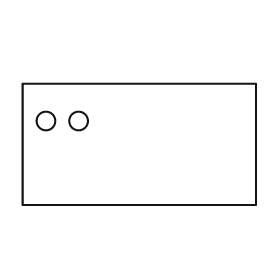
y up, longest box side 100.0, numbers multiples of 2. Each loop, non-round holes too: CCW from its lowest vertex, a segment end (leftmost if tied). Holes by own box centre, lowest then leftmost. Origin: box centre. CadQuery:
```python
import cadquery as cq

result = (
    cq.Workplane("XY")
    .moveTo(-50.0, -26.0)
    .lineTo(50.0, -26.0)
    .lineTo(50.0, 26.0)
    .lineTo(-50.0, 26.0)
    .close()
    .moveTo(-40.0, 10.0)
    .circle(4.0)
    .moveTo(-26.0, 10.0)
    .circle(4.0)
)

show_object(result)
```